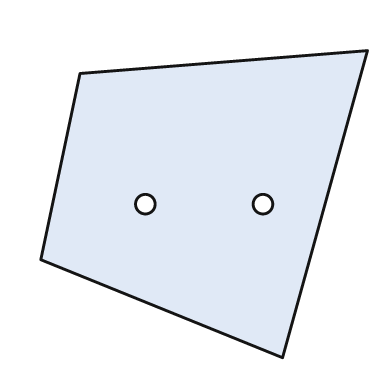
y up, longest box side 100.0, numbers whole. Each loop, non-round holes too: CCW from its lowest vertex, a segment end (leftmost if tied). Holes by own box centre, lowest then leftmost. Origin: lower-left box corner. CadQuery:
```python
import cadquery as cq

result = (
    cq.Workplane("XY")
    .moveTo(74.0, 0.0)
    .lineTo(100.0, 94.0)
    .lineTo(12.0, 87.0)
    .lineTo(0.0, 30.0)
    .close()
    .moveTo(32.0, 47.0)
    .circle(3.0)
    .moveTo(68.0, 47.0)
    .circle(3.0)
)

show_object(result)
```